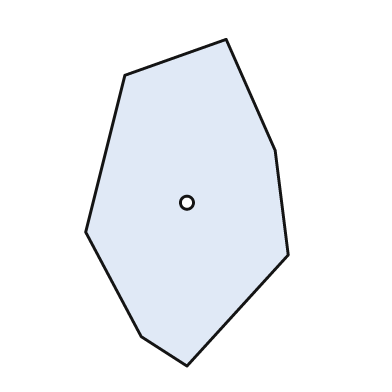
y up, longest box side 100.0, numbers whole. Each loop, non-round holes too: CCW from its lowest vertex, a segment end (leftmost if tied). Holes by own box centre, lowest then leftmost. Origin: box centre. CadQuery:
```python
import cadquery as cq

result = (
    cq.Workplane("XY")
    .moveTo(0.0, -50.0)
    .lineTo(31.0, -16.0)
    .lineTo(27.0, 16.0)
    .lineTo(12.0, 50.0)
    .lineTo(-19.0, 39.0)
    .lineTo(-31.0, -9.0)
    .lineTo(-14.0, -41.0)
    .close()
    .moveTo(0.0, 0.0)
    .circle(2.0)
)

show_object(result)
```